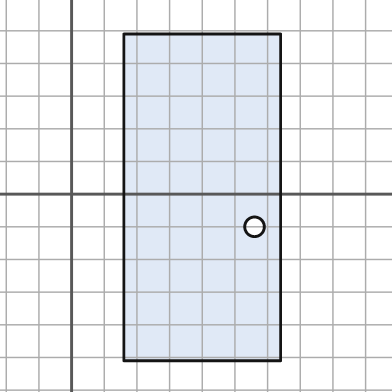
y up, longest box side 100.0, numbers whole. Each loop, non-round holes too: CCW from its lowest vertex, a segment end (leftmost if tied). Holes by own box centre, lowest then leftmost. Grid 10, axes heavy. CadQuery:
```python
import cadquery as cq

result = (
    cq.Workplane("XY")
    .moveTo(16.0, -51.0)
    .lineTo(64.0, -51.0)
    .lineTo(64.0, 49.0)
    .lineTo(16.0, 49.0)
    .close()
    .moveTo(56.0, -10.0)
    .circle(3.0)
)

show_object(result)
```